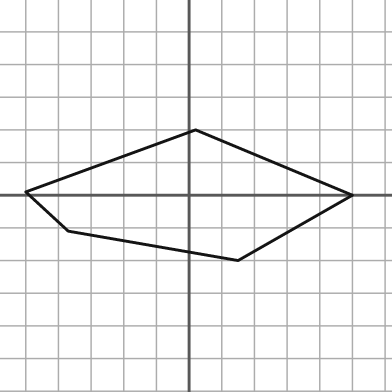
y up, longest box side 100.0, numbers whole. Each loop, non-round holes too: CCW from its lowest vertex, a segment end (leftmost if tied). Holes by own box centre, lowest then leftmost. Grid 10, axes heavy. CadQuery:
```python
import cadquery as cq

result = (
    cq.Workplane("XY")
    .moveTo(15.0, -20.0)
    .lineTo(50.0, 0.0)
    .lineTo(2.0, 20.0)
    .lineTo(-50.0, 1.0)
    .lineTo(-37.0, -11.0)
    .close()
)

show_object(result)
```